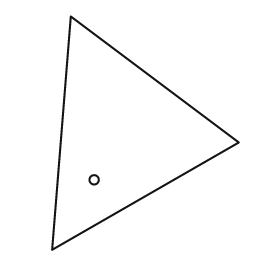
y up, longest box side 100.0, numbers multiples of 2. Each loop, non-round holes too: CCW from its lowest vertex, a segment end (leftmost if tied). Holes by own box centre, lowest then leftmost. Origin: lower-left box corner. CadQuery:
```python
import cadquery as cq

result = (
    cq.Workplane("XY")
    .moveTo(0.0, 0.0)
    .lineTo(80.0, 46.0)
    .lineTo(8.0, 100.0)
    .close()
    .moveTo(18.0, 30.0)
    .circle(2.0)
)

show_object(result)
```